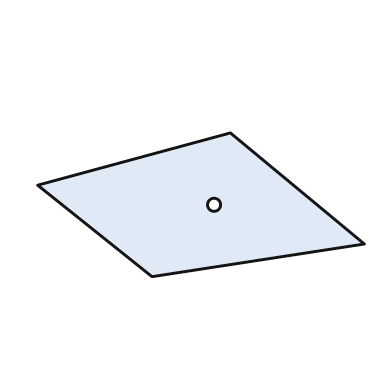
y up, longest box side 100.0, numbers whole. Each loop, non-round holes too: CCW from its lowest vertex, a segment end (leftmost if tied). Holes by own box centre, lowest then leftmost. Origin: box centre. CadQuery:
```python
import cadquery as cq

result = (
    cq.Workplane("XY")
    .moveTo(-15.0, -22.0)
    .lineTo(50.0, -12.0)
    .lineTo(9.0, 22.0)
    .lineTo(-50.0, 6.0)
    .close()
    .moveTo(4.0, 0.0)
    .circle(2.0)
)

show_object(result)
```